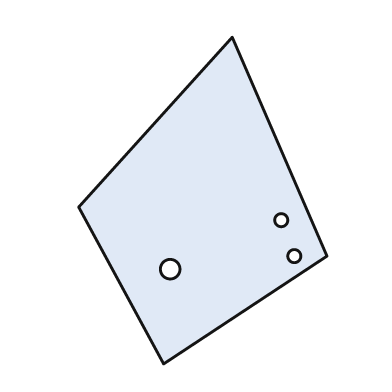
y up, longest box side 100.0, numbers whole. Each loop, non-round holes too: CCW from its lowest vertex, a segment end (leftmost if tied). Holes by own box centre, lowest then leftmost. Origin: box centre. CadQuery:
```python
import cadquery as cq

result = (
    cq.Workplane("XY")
    .moveTo(-12.0, -50.0)
    .lineTo(38.0, -17.0)
    .lineTo(9.0, 50.0)
    .lineTo(-38.0, -2.0)
    .close()
    .moveTo(-10.0, -21.0)
    .circle(3.0)
    .moveTo(28.0, -17.0)
    .circle(2.0)
    .moveTo(24.0, -6.0)
    .circle(2.0)
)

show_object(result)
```